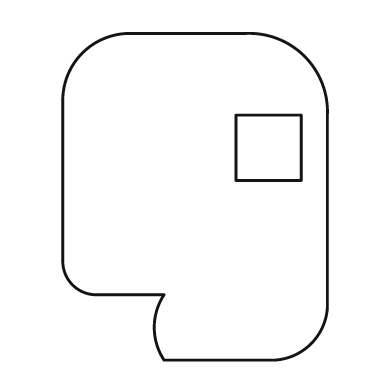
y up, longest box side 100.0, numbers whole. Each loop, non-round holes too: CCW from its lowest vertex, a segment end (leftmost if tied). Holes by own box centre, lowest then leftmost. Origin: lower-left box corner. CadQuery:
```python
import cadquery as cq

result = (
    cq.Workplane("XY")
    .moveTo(31.0, 0.0)
    .lineTo(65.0, 0.0)
    .threePointArc((76.0, 5.0), (81.0, 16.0))
    .lineTo(81.0, 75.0)
    .threePointArc((74.0, 93.0), (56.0, 100.0))
    .lineTo(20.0, 100.0)
    .threePointArc((6.0, 94.0), (0.0, 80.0))
    .lineTo(0.0, 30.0)
    .threePointArc((3.0, 23.0), (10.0, 20.0))
    .lineTo(31.0, 20.0)
    .threePointArc((28.0, 10.0), (31.0, 0.0))
    .close()
    .moveTo(53.0, 55.0)
    .lineTo(73.0, 55.0)
    .lineTo(73.0, 75.0)
    .lineTo(53.0, 75.0)
    .close()
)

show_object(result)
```